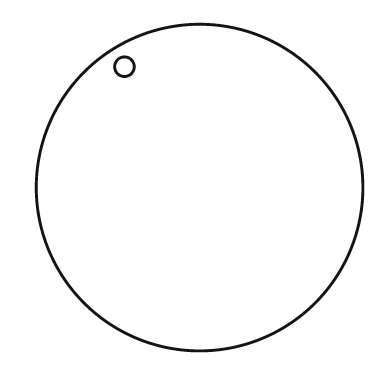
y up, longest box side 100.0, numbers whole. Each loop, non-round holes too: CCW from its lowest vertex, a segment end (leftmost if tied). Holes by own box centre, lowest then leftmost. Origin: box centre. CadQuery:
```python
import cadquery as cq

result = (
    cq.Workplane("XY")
    .moveTo(0.0, 0.0)
    .circle(50.0)
    .moveTo(-23.0, 37.0)
    .circle(3.0)
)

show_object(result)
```